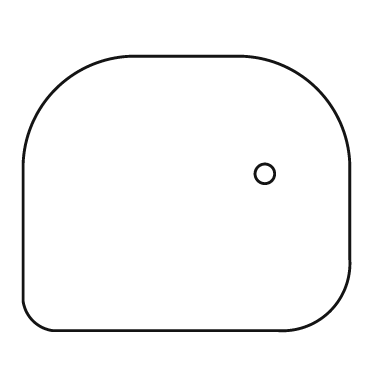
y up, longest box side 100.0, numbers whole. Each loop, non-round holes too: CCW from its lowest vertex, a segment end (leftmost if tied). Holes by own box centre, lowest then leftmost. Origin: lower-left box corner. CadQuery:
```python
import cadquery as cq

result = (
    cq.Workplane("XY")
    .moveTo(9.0, 0.0)
    .lineTo(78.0, 0.0)
    .threePointArc((94.0, 6.0), (100.0, 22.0))
    .lineTo(100.0, 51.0)
    .threePointArc((90.0, 74.0), (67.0, 84.0))
    .lineTo(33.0, 84.0)
    .threePointArc((10.0, 74.0), (0.0, 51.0))
    .lineTo(0.0, 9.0)
    .threePointArc((3.0, 3.0), (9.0, 0.0))
    .close()
    .moveTo(74.0, 48.0)
    .circle(3.0)
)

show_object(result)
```